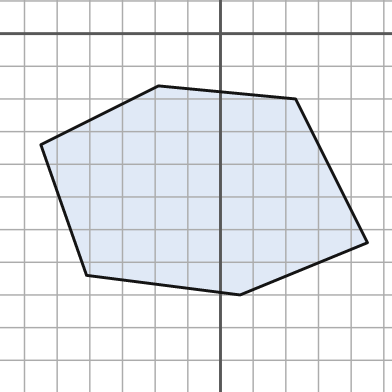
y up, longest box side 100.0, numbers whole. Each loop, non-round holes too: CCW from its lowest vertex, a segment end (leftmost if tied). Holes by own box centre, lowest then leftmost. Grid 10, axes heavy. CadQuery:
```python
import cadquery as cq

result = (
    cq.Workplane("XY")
    .moveTo(6.0, -80.0)
    .lineTo(45.0, -64.0)
    .lineTo(23.0, -20.0)
    .lineTo(-19.0, -16.0)
    .lineTo(-55.0, -34.0)
    .lineTo(-41.0, -74.0)
    .close()
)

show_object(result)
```